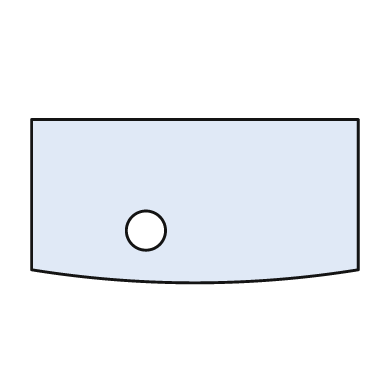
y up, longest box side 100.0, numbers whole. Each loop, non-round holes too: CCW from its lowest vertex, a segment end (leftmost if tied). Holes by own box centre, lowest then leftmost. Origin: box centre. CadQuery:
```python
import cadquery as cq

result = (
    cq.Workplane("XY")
    .moveTo(-50.0, -21.0)
    .threePointArc((0.0, -25.0), (50.0, -21.0))
    .lineTo(50.0, 25.0)
    .lineTo(-50.0, 25.0)
    .close()
    .moveTo(-15.0, -9.0)
    .circle(6.0)
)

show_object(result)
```